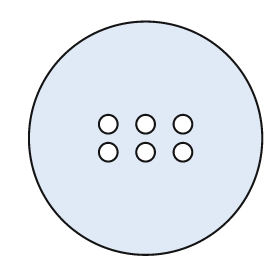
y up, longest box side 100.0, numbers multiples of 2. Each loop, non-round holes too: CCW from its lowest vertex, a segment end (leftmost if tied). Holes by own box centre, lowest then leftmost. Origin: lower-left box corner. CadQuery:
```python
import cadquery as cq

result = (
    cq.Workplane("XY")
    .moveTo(50.0, 50.0)
    .circle(50.0)
    .moveTo(34.0, 44.0)
    .circle(4.0)
    .moveTo(50.0, 44.0)
    .circle(4.0)
    .moveTo(66.0, 44.0)
    .circle(4.0)
    .moveTo(34.0, 56.0)
    .circle(4.0)
    .moveTo(50.0, 56.0)
    .circle(4.0)
    .moveTo(66.0, 56.0)
    .circle(4.0)
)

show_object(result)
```